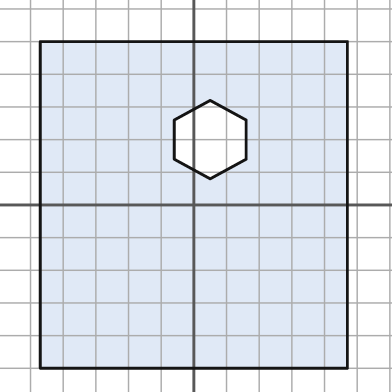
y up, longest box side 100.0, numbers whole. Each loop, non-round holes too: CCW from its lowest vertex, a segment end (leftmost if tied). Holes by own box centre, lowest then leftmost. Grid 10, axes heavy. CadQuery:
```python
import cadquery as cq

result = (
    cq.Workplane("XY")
    .moveTo(-47.0, -50.0)
    .lineTo(47.0, -50.0)
    .lineTo(47.0, 50.0)
    .lineTo(-47.0, 50.0)
    .close()
    .moveTo(5.0, 8.0)
    .lineTo(16.0, 14.0)
    .lineTo(16.0, 26.0)
    .lineTo(5.0, 32.0)
    .lineTo(-6.0, 26.0)
    .lineTo(-6.0, 14.0)
    .close()
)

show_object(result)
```